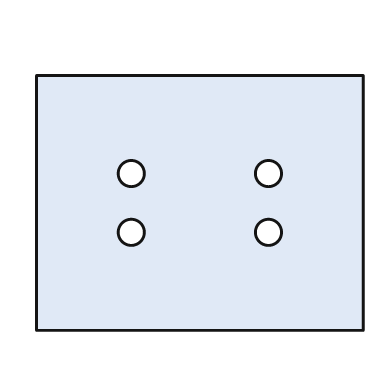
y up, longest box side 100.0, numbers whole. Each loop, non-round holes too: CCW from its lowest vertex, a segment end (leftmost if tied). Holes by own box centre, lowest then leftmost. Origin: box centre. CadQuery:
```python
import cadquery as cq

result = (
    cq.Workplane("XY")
    .moveTo(-50.0, -39.0)
    .lineTo(50.0, -39.0)
    .lineTo(50.0, 39.0)
    .lineTo(-50.0, 39.0)
    .close()
    .moveTo(-21.0, -9.0)
    .circle(4.0)
    .moveTo(21.0, -9.0)
    .circle(4.0)
    .moveTo(-21.0, 9.0)
    .circle(4.0)
    .moveTo(21.0, 9.0)
    .circle(4.0)
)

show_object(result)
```